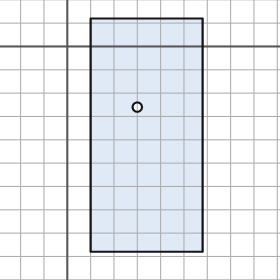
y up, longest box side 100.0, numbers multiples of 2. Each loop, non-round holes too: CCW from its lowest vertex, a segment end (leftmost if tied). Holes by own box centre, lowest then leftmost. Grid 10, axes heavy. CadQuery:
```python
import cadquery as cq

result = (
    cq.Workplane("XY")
    .moveTo(10.0, -88.0)
    .lineTo(58.0, -88.0)
    .lineTo(58.0, 12.0)
    .lineTo(10.0, 12.0)
    .close()
    .moveTo(30.0, -26.0)
    .circle(2.0)
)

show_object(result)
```